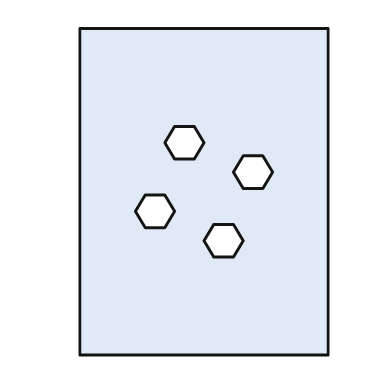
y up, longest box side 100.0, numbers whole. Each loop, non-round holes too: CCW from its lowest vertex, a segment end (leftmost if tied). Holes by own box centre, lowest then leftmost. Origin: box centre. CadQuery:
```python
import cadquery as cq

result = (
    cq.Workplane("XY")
    .moveTo(-38.0, -50.0)
    .lineTo(38.0, -50.0)
    .lineTo(38.0, 50.0)
    .lineTo(-38.0, 50.0)
    .close()
    .moveTo(3.0, -20.0)
    .lineTo(9.0, -20.0)
    .lineTo(12.0, -15.0)
    .lineTo(9.0, -10.0)
    .lineTo(3.0, -10.0)
    .lineTo(0.0, -15.0)
    .close()
    .moveTo(-18.0, -11.0)
    .lineTo(-12.0, -11.0)
    .lineTo(-9.0, -6.0)
    .lineTo(-12.0, -1.0)
    .lineTo(-18.0, -1.0)
    .lineTo(-21.0, -6.0)
    .close()
    .moveTo(12.0, 1.0)
    .lineTo(18.0, 1.0)
    .lineTo(21.0, 6.0)
    .lineTo(18.0, 11.0)
    .lineTo(12.0, 11.0)
    .lineTo(9.0, 6.0)
    .close()
    .moveTo(-9.0, 10.0)
    .lineTo(-3.0, 10.0)
    .lineTo(0.0, 15.0)
    .lineTo(-3.0, 20.0)
    .lineTo(-9.0, 20.0)
    .lineTo(-12.0, 15.0)
    .close()
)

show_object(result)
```